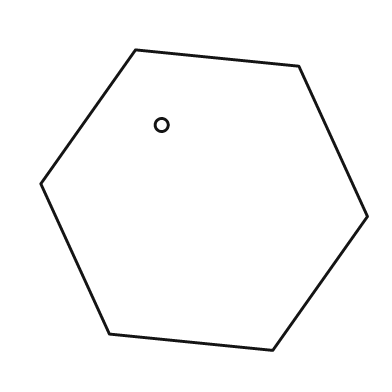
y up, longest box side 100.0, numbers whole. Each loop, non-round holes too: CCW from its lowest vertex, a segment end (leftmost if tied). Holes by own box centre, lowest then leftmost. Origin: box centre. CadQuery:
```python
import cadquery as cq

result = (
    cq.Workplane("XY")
    .moveTo(21.0, -46.0)
    .lineTo(50.0, -5.0)
    .lineTo(29.0, 41.0)
    .lineTo(-21.0, 46.0)
    .lineTo(-50.0, 5.0)
    .lineTo(-29.0, -41.0)
    .close()
    .moveTo(-13.0, 23.0)
    .circle(2.0)
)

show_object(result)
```